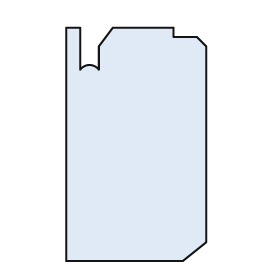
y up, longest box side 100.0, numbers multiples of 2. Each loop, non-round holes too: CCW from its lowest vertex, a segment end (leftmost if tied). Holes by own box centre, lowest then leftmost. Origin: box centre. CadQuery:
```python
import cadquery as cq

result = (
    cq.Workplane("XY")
    .moveTo(-30.0, -50.0)
    .lineTo(20.0, -50.0)
    .lineTo(30.0, -42.0)
    .lineTo(30.0, 42.0)
    .lineTo(26.0, 46.0)
    .lineTo(16.0, 46.0)
    .lineTo(16.0, 50.0)
    .lineTo(-10.0, 50.0)
    .lineTo(-16.0, 42.0)
    .lineTo(-16.0, 32.0)
    .threePointArc((-20.0, 34.0), (-24.0, 32.0))
    .lineTo(-24.0, 50.0)
    .lineTo(-30.0, 50.0)
    .close()
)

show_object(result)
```